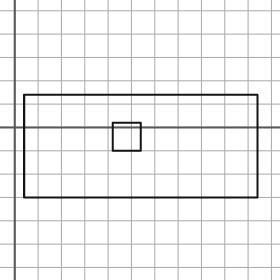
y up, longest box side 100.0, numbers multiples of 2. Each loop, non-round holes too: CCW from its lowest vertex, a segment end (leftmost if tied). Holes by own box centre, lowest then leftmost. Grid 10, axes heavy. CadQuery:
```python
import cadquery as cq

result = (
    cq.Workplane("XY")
    .moveTo(4.0, -30.0)
    .lineTo(104.0, -30.0)
    .lineTo(104.0, 14.0)
    .lineTo(4.0, 14.0)
    .close()
    .moveTo(42.0, -10.0)
    .lineTo(54.0, -10.0)
    .lineTo(54.0, 2.0)
    .lineTo(42.0, 2.0)
    .close()
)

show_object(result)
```